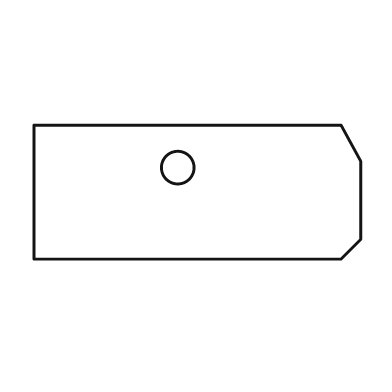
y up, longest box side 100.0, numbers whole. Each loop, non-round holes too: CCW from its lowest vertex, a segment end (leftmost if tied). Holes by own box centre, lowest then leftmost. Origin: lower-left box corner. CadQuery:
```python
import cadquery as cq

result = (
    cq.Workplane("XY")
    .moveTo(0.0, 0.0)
    .lineTo(94.0, 0.0)
    .lineTo(100.0, 6.0)
    .lineTo(100.0, 30.0)
    .lineTo(94.0, 41.0)
    .lineTo(0.0, 41.0)
    .close()
    .moveTo(44.0, 28.0)
    .circle(5.0)
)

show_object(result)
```